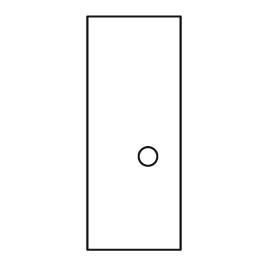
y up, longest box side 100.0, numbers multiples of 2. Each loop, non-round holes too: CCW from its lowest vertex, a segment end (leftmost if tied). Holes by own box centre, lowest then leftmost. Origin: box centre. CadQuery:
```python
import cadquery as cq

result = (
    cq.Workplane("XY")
    .moveTo(-20.0, -50.0)
    .lineTo(20.0, -50.0)
    .lineTo(20.0, 50.0)
    .lineTo(-20.0, 50.0)
    .close()
    .moveTo(6.0, -10.0)
    .circle(4.0)
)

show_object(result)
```